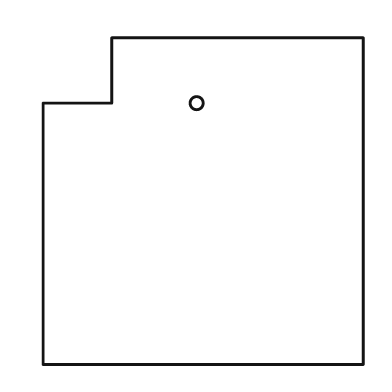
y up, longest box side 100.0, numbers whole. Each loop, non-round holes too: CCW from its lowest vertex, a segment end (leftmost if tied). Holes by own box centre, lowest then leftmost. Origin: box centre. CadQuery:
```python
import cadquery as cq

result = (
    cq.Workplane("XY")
    .moveTo(-49.0, -50.0)
    .lineTo(49.0, -50.0)
    .lineTo(49.0, 50.0)
    .lineTo(-28.0, 50.0)
    .lineTo(-28.0, 30.0)
    .lineTo(-49.0, 30.0)
    .close()
    .moveTo(-2.0, 30.0)
    .circle(2.0)
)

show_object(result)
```